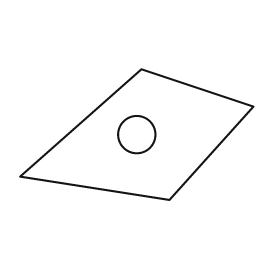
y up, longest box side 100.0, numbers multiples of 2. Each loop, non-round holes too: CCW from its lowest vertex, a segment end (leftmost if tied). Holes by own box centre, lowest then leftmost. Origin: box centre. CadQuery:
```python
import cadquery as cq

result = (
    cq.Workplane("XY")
    .moveTo(14.0, -28.0)
    .lineTo(50.0, 12.0)
    .lineTo(2.0, 28.0)
    .lineTo(-50.0, -18.0)
    .close()
    .moveTo(0.0, 0.0)
    .circle(8.0)
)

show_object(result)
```